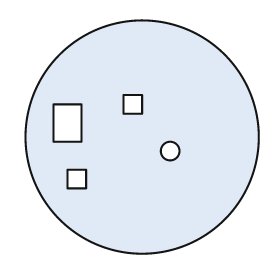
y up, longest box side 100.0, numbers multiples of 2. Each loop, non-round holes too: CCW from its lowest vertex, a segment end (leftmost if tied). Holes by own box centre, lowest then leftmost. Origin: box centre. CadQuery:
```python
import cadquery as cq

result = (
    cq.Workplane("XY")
    .moveTo(0.0, 0.0)
    .circle(50.0)
    .moveTo(-32.0, -22.0)
    .lineTo(-24.0, -22.0)
    .lineTo(-24.0, -14.0)
    .lineTo(-32.0, -14.0)
    .close()
    .moveTo(12.0, -6.0)
    .circle(4.0)
    .moveTo(-38.0, -2.0)
    .lineTo(-26.0, -2.0)
    .lineTo(-26.0, 14.0)
    .lineTo(-38.0, 14.0)
    .close()
    .moveTo(-8.0, 10.0)
    .lineTo(0.0, 10.0)
    .lineTo(0.0, 18.0)
    .lineTo(-8.0, 18.0)
    .close()
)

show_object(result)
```